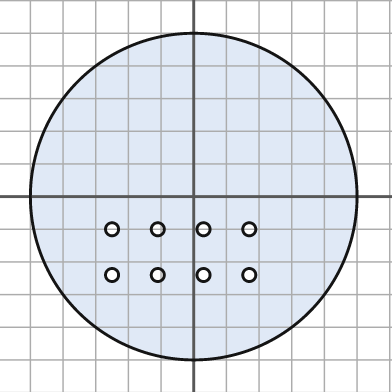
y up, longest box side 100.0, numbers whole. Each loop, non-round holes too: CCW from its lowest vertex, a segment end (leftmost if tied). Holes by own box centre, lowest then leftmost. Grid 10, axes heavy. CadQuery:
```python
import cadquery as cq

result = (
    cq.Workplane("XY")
    .moveTo(0.0, 0.0)
    .circle(50.0)
    .moveTo(-25.0, -24.0)
    .circle(2.0)
    .moveTo(-11.0, -24.0)
    .circle(2.0)
    .moveTo(3.0, -24.0)
    .circle(2.0)
    .moveTo(17.0, -24.0)
    .circle(2.0)
    .moveTo(-25.0, -10.0)
    .circle(2.0)
    .moveTo(-11.0, -10.0)
    .circle(2.0)
    .moveTo(3.0, -10.0)
    .circle(2.0)
    .moveTo(17.0, -10.0)
    .circle(2.0)
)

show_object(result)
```